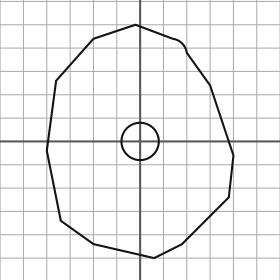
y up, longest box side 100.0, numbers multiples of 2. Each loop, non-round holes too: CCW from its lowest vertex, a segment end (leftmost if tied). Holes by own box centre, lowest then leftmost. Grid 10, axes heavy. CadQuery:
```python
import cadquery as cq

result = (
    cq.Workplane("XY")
    .moveTo(6.0, -50.0)
    .lineTo(18.0, -44.0)
    .lineTo(38.0, -24.0)
    .lineTo(40.0, -6.0)
    .lineTo(30.0, 24.0)
    .lineTo(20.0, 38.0)
    .threePointArc((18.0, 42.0), (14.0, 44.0))
    .lineTo(-2.0, 50.0)
    .lineTo(-20.0, 44.0)
    .lineTo(-36.0, 26.0)
    .lineTo(-40.0, -4.0)
    .lineTo(-34.0, -34.0)
    .lineTo(-20.0, -44.0)
    .close()
    .moveTo(0.0, 0.0)
    .circle(8.0)
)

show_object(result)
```